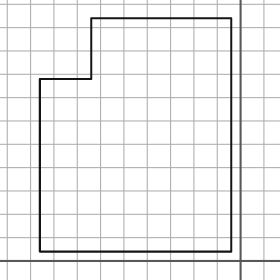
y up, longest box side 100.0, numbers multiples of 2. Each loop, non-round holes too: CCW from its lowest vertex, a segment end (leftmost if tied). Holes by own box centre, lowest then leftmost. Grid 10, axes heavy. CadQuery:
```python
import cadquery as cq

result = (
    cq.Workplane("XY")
    .moveTo(-86.0, 4.0)
    .lineTo(-4.0, 4.0)
    .lineTo(-4.0, 104.0)
    .lineTo(-64.0, 104.0)
    .lineTo(-64.0, 78.0)
    .lineTo(-86.0, 78.0)
    .close()
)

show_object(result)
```